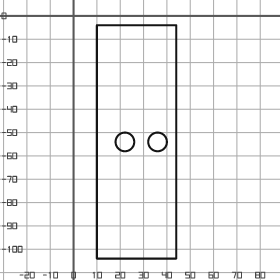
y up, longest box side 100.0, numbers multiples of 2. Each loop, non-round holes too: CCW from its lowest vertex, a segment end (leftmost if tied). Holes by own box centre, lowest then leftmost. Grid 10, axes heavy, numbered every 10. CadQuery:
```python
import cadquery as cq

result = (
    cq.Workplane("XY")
    .moveTo(10.0, -104.0)
    .lineTo(44.0, -104.0)
    .lineTo(44.0, -4.0)
    .lineTo(10.0, -4.0)
    .close()
    .moveTo(22.0, -54.0)
    .circle(4.0)
    .moveTo(36.0, -54.0)
    .circle(4.0)
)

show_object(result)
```